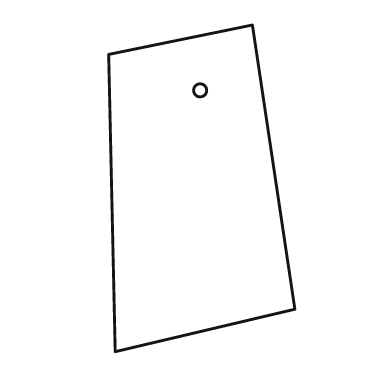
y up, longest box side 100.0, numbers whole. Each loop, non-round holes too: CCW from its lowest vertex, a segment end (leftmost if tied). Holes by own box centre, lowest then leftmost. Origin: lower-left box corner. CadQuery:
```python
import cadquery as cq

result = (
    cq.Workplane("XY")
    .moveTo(2.0, 0.0)
    .lineTo(57.0, 13.0)
    .lineTo(44.0, 100.0)
    .lineTo(0.0, 91.0)
    .close()
    .moveTo(28.0, 80.0)
    .circle(2.0)
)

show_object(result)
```